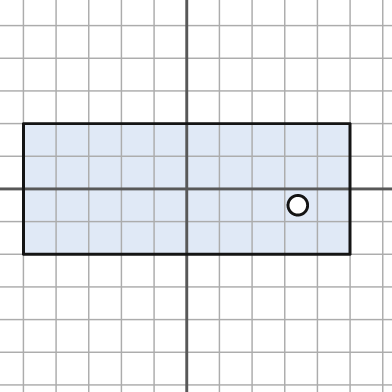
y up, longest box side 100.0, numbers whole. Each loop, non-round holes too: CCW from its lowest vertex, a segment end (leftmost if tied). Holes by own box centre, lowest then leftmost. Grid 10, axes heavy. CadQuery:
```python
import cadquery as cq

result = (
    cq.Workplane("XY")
    .moveTo(-50.0, -20.0)
    .lineTo(50.0, -20.0)
    .lineTo(50.0, 20.0)
    .lineTo(-50.0, 20.0)
    .close()
    .moveTo(34.0, -5.0)
    .circle(3.0)
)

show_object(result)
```